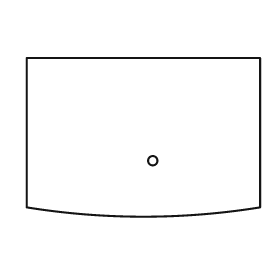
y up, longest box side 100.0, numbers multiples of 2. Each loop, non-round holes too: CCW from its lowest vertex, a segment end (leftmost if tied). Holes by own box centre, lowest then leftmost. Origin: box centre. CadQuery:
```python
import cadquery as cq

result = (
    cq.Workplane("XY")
    .moveTo(-50.0, -30.0)
    .threePointArc((0.0, -34.0), (50.0, -30.0))
    .lineTo(50.0, 34.0)
    .lineTo(-50.0, 34.0)
    .close()
    .moveTo(4.0, -10.0)
    .circle(2.0)
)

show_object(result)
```